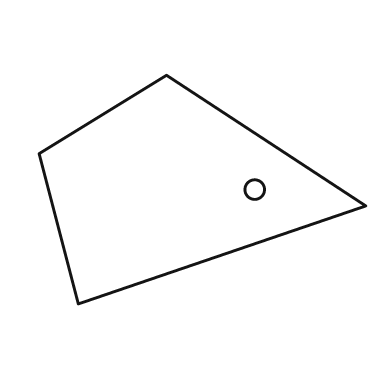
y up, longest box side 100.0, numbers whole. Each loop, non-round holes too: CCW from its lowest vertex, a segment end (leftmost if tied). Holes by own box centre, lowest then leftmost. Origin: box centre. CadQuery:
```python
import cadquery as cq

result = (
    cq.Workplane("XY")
    .moveTo(-38.0, -35.0)
    .lineTo(50.0, -5.0)
    .lineTo(-11.0, 35.0)
    .lineTo(-50.0, 11.0)
    .close()
    .moveTo(16.0, 0.0)
    .circle(3.0)
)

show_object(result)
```